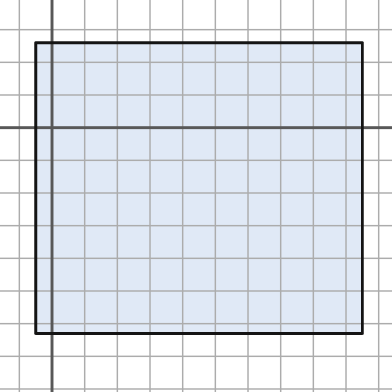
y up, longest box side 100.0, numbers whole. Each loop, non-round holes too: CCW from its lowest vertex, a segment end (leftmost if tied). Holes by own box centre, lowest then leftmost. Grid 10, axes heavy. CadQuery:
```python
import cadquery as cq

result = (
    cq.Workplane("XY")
    .moveTo(-5.0, -63.0)
    .lineTo(95.0, -63.0)
    .lineTo(95.0, 26.0)
    .lineTo(-5.0, 26.0)
    .close()
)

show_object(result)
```